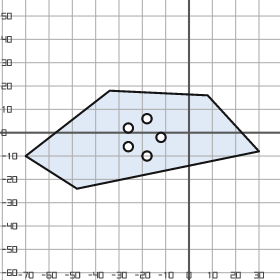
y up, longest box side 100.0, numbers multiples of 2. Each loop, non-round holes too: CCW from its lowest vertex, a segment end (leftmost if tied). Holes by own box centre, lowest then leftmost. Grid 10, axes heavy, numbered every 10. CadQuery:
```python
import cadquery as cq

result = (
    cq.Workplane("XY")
    .moveTo(-48.0, -24.0)
    .lineTo(30.0, -8.0)
    .lineTo(8.0, 16.0)
    .lineTo(-34.0, 18.0)
    .lineTo(-70.0, -10.0)
    .close()
    .moveTo(-18.0, -10.0)
    .circle(2.0)
    .moveTo(-26.0, -6.0)
    .circle(2.0)
    .moveTo(-12.0, -2.0)
    .circle(2.0)
    .moveTo(-26.0, 2.0)
    .circle(2.0)
    .moveTo(-18.0, 6.0)
    .circle(2.0)
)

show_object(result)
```